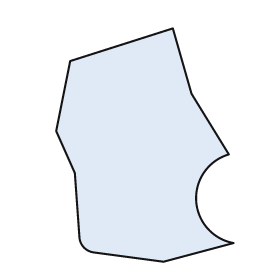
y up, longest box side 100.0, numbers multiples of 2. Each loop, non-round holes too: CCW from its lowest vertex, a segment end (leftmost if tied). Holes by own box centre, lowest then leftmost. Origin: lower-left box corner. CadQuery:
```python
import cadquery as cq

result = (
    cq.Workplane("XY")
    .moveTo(46.0, 0.0)
    .lineTo(76.0, 8.0)
    .threePointArc((60.0, 26.0), (74.0, 46.0))
    .lineTo(58.0, 72.0)
    .lineTo(50.0, 100.0)
    .lineTo(6.0, 86.0)
    .lineTo(0.0, 56.0)
    .lineTo(8.0, 38.0)
    .lineTo(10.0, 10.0)
    .threePointArc((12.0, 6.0), (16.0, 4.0))
    .close()
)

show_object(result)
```